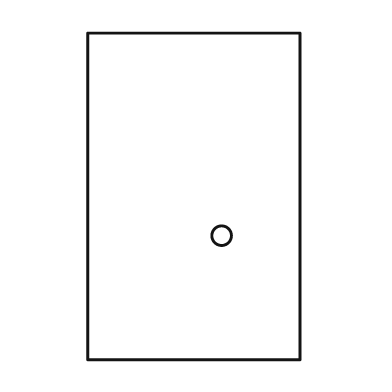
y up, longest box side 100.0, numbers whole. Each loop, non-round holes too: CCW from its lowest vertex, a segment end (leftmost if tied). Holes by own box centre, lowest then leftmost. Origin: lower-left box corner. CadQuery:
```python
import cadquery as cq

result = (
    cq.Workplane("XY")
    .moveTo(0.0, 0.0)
    .lineTo(65.0, 0.0)
    .lineTo(65.0, 100.0)
    .lineTo(0.0, 100.0)
    .close()
    .moveTo(41.0, 38.0)
    .circle(3.0)
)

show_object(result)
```